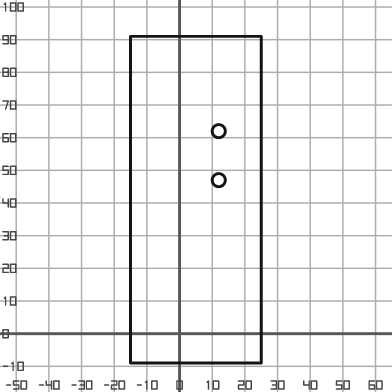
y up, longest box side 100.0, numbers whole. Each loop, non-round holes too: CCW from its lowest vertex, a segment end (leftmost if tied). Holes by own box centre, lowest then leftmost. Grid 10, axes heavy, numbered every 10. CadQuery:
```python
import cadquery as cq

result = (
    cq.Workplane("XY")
    .moveTo(-15.0, -9.0)
    .lineTo(25.0, -9.0)
    .lineTo(25.0, 91.0)
    .lineTo(-15.0, 91.0)
    .close()
    .moveTo(12.0, 47.0)
    .circle(2.0)
    .moveTo(12.0, 62.0)
    .circle(2.0)
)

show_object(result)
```